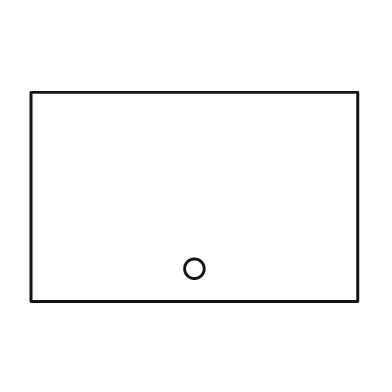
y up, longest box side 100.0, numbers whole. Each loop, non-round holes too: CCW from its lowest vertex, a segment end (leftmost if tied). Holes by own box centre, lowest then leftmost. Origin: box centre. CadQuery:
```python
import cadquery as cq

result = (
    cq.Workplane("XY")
    .moveTo(-50.0, -32.0)
    .lineTo(50.0, -32.0)
    .lineTo(50.0, 32.0)
    .lineTo(-50.0, 32.0)
    .close()
    .moveTo(0.0, -22.0)
    .circle(3.0)
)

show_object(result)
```